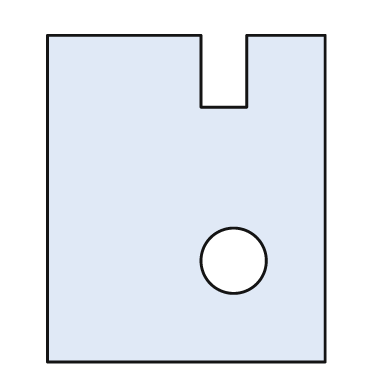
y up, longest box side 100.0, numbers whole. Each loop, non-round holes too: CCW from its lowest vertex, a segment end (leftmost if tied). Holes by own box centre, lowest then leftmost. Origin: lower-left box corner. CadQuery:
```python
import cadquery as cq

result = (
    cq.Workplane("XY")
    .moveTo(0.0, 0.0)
    .lineTo(85.0, 0.0)
    .lineTo(85.0, 100.0)
    .lineTo(61.0, 100.0)
    .lineTo(61.0, 78.0)
    .lineTo(47.0, 78.0)
    .lineTo(47.0, 100.0)
    .lineTo(0.0, 100.0)
    .close()
    .moveTo(57.0, 31.0)
    .circle(10.0)
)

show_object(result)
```